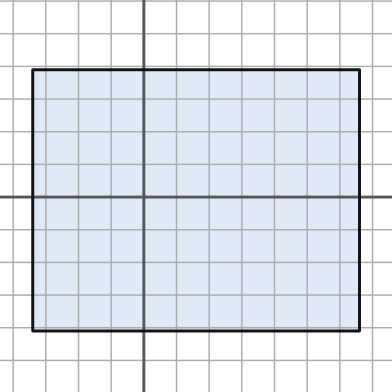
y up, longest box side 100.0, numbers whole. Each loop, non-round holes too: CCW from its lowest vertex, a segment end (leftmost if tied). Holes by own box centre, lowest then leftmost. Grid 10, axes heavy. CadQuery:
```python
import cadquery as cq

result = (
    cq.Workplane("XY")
    .moveTo(-34.0, -41.0)
    .lineTo(66.0, -41.0)
    .lineTo(66.0, 39.0)
    .lineTo(-34.0, 39.0)
    .close()
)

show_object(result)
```